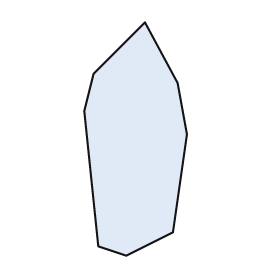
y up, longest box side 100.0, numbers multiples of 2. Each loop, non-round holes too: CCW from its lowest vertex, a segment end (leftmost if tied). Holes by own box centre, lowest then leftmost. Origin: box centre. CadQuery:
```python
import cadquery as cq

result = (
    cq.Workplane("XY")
    .moveTo(-4.0, -50.0)
    .lineTo(16.0, -40.0)
    .lineTo(22.0, 2.0)
    .lineTo(18.0, 24.0)
    .lineTo(4.0, 50.0)
    .lineTo(-18.0, 28.0)
    .lineTo(-22.0, 12.0)
    .lineTo(-16.0, -46.0)
    .close()
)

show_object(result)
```